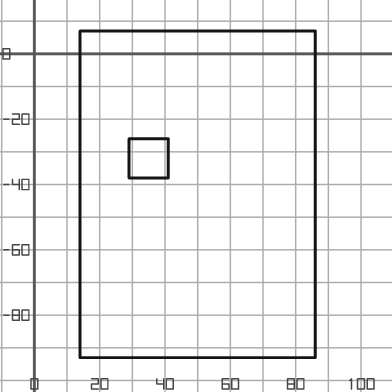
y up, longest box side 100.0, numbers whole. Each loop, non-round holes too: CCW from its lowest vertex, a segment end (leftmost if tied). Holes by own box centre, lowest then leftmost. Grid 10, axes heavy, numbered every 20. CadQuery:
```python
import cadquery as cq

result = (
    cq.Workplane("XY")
    .moveTo(14.0, -93.0)
    .lineTo(86.0, -93.0)
    .lineTo(86.0, 7.0)
    .lineTo(14.0, 7.0)
    .close()
    .moveTo(29.0, -38.0)
    .lineTo(41.0, -38.0)
    .lineTo(41.0, -26.0)
    .lineTo(29.0, -26.0)
    .close()
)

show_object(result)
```